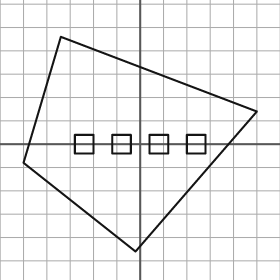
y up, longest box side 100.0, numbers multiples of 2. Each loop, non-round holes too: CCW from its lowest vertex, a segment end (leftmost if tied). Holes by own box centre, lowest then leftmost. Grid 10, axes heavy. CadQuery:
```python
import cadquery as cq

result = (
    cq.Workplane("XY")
    .moveTo(-2.0, -46.0)
    .lineTo(50.0, 14.0)
    .lineTo(-34.0, 46.0)
    .lineTo(-50.0, -8.0)
    .close()
    .moveTo(-28.0, -4.0)
    .lineTo(-20.0, -4.0)
    .lineTo(-20.0, 4.0)
    .lineTo(-28.0, 4.0)
    .close()
    .moveTo(-12.0, -4.0)
    .lineTo(-4.0, -4.0)
    .lineTo(-4.0, 4.0)
    .lineTo(-12.0, 4.0)
    .close()
    .moveTo(4.0, -4.0)
    .lineTo(12.0, -4.0)
    .lineTo(12.0, 4.0)
    .lineTo(4.0, 4.0)
    .close()
    .moveTo(20.0, -4.0)
    .lineTo(28.0, -4.0)
    .lineTo(28.0, 4.0)
    .lineTo(20.0, 4.0)
    .close()
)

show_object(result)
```